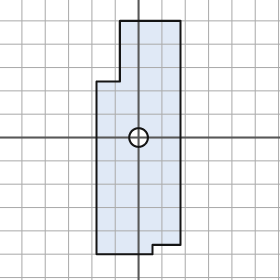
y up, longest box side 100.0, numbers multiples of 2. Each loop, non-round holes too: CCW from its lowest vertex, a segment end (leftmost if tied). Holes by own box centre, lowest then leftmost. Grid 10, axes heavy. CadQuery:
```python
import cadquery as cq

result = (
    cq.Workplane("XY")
    .moveTo(-18.0, -50.0)
    .lineTo(6.0, -50.0)
    .lineTo(6.0, -46.0)
    .lineTo(18.0, -46.0)
    .lineTo(18.0, 50.0)
    .lineTo(-8.0, 50.0)
    .lineTo(-8.0, 24.0)
    .lineTo(-18.0, 24.0)
    .close()
    .moveTo(0.0, 0.0)
    .circle(4.0)
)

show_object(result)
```